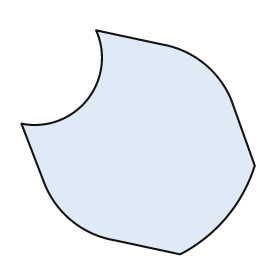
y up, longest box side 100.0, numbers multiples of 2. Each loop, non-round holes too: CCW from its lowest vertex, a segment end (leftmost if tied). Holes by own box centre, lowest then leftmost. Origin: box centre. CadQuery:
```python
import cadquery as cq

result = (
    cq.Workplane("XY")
    .moveTo(18.0, -48.0)
    .threePointArc((38.0, -32.0), (50.0, -10.0))
    .lineTo(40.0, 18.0)
    .threePointArc((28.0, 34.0), (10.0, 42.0))
    .lineTo(-18.0, 48.0)
    .threePointArc((-22.0, 18.0), (-50.0, 8.0))
    .lineTo(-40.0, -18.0)
    .threePointArc((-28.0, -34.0), (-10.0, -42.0))
    .close()
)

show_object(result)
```